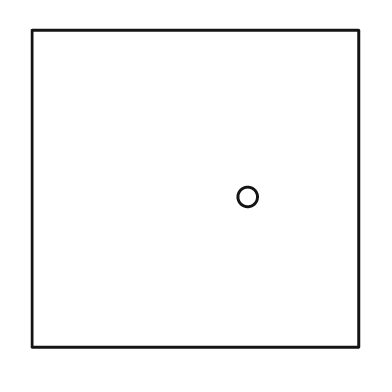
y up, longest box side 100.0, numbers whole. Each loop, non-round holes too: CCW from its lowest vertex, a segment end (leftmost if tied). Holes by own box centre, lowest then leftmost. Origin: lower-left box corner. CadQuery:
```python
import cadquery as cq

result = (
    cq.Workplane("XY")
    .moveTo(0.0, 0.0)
    .lineTo(100.0, 0.0)
    .lineTo(100.0, 97.0)
    .lineTo(0.0, 97.0)
    .close()
    .moveTo(66.0, 46.0)
    .circle(3.0)
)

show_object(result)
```